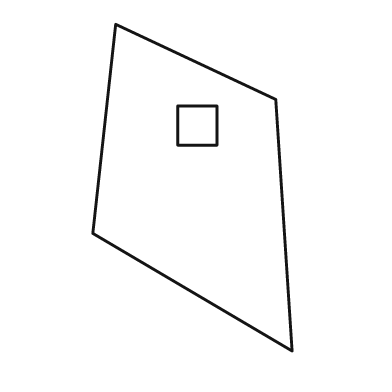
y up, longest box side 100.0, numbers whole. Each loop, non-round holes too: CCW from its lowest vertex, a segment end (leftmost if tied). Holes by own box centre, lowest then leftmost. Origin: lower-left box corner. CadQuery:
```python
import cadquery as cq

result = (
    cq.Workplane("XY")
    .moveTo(61.0, 0.0)
    .lineTo(56.0, 77.0)
    .lineTo(7.0, 100.0)
    .lineTo(0.0, 36.0)
    .close()
    .moveTo(26.0, 63.0)
    .lineTo(38.0, 63.0)
    .lineTo(38.0, 75.0)
    .lineTo(26.0, 75.0)
    .close()
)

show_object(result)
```